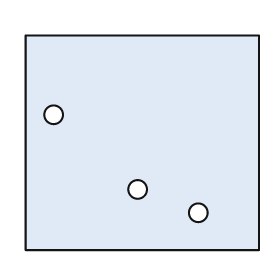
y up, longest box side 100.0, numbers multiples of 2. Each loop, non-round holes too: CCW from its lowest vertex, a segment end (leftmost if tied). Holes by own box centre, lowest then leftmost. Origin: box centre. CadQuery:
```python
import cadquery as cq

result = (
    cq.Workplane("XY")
    .moveTo(-50.0, -46.0)
    .lineTo(50.0, -46.0)
    .lineTo(50.0, 46.0)
    .lineTo(-50.0, 46.0)
    .close()
    .moveTo(24.0, -30.0)
    .circle(4.0)
    .moveTo(-2.0, -20.0)
    .circle(4.0)
    .moveTo(-38.0, 12.0)
    .circle(4.0)
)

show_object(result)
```